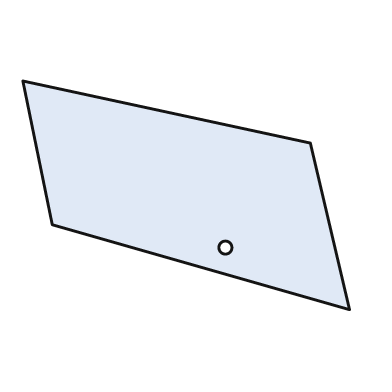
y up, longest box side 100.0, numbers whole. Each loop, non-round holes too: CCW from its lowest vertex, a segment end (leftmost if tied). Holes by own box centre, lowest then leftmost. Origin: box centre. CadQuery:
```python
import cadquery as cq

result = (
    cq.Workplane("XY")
    .moveTo(50.0, -35.0)
    .lineTo(38.0, 16.0)
    .lineTo(-50.0, 35.0)
    .lineTo(-41.0, -9.0)
    .close()
    .moveTo(12.0, -16.0)
    .circle(2.0)
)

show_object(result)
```